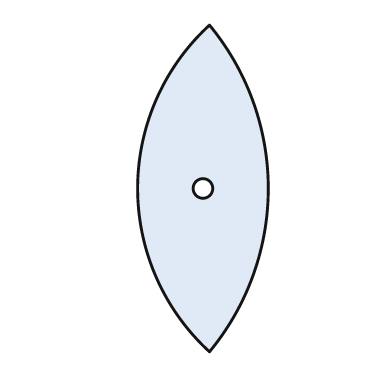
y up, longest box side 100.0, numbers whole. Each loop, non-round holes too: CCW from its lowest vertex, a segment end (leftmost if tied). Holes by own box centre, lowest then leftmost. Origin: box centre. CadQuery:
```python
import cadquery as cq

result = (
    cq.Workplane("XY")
    .moveTo(2.0, -50.0)
    .threePointArc((20.0, 0.0), (2.0, 50.0))
    .threePointArc((-20.0, 0.0), (2.0, -50.0))
    .close()
    .moveTo(0.0, 0.0)
    .circle(3.0)
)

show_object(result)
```